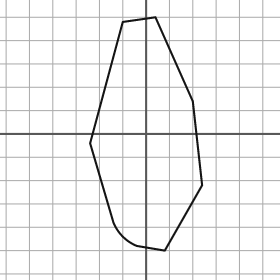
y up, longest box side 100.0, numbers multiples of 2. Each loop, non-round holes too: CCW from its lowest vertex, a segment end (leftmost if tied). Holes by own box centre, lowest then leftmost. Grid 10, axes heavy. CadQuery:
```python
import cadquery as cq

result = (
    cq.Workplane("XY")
    .moveTo(8.0, -50.0)
    .lineTo(24.0, -22.0)
    .lineTo(20.0, 14.0)
    .lineTo(4.0, 50.0)
    .lineTo(-10.0, 48.0)
    .lineTo(-24.0, -4.0)
    .lineTo(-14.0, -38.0)
    .threePointArc((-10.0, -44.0), (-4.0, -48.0))
    .close()
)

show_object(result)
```